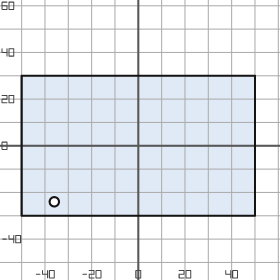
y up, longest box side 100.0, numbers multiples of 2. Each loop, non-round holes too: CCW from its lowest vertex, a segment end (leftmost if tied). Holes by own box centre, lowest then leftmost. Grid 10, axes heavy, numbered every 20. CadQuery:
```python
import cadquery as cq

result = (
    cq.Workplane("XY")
    .moveTo(-50.0, -30.0)
    .lineTo(50.0, -30.0)
    .lineTo(50.0, 30.0)
    .lineTo(-50.0, 30.0)
    .close()
    .moveTo(-36.0, -24.0)
    .circle(2.0)
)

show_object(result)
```